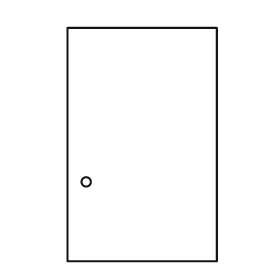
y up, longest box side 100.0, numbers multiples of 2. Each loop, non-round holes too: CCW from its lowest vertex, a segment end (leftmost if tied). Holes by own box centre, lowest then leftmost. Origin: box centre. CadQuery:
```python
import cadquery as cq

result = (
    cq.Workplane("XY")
    .moveTo(-32.0, -50.0)
    .lineTo(32.0, -50.0)
    .lineTo(32.0, 50.0)
    .lineTo(-32.0, 50.0)
    .close()
    .moveTo(-24.0, -16.0)
    .circle(2.0)
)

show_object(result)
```